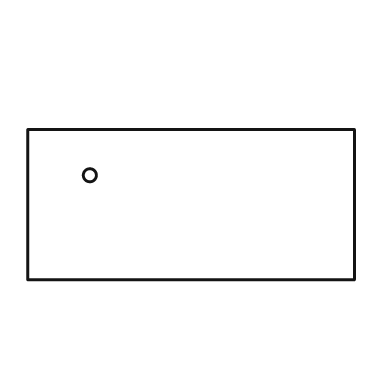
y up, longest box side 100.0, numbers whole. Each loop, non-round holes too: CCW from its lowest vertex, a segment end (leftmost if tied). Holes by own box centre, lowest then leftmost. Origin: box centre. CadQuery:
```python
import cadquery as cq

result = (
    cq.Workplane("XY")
    .moveTo(-50.0, -23.0)
    .lineTo(50.0, -23.0)
    .lineTo(50.0, 23.0)
    .lineTo(-50.0, 23.0)
    .close()
    .moveTo(-31.0, 9.0)
    .circle(2.0)
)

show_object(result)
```